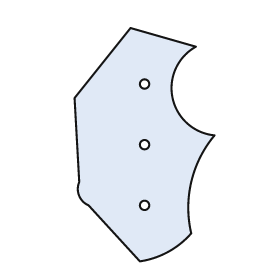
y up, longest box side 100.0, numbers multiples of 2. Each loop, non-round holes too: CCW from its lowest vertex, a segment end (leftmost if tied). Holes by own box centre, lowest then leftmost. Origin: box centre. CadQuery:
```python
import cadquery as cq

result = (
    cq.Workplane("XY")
    .moveTo(-2.0, -50.0)
    .threePointArc((10.0, -46.0), (20.0, -38.0))
    .threePointArc((20.0, -16.0), (30.0, 4.0))
    .threePointArc((12.0, 20.0), (22.0, 42.0))
    .lineTo(-6.0, 50.0)
    .lineTo(-30.0, 20.0)
    .lineTo(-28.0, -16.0)
    .threePointArc((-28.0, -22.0), (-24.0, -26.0))
    .close()
    .moveTo(0.0, -26.0)
    .circle(2.0)
    .moveTo(0.0, 0.0)
    .circle(2.0)
    .moveTo(0.0, 26.0)
    .circle(2.0)
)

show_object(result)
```